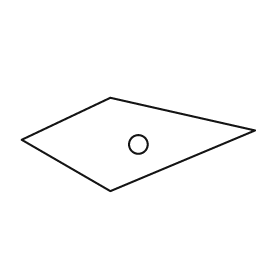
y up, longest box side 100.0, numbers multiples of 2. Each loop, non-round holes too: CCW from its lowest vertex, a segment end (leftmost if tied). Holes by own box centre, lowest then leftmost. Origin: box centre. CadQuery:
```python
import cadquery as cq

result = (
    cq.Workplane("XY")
    .moveTo(-12.0, -20.0)
    .lineTo(50.0, 6.0)
    .lineTo(-12.0, 20.0)
    .lineTo(-50.0, 2.0)
    .close()
    .moveTo(0.0, 0.0)
    .circle(4.0)
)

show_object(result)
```